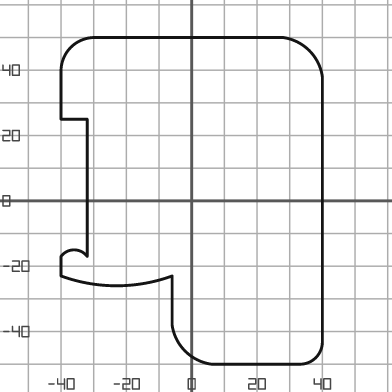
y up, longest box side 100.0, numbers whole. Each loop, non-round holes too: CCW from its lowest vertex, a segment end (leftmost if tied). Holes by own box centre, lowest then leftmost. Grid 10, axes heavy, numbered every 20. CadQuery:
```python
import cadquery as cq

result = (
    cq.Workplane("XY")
    .moveTo(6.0, -50.0)
    .lineTo(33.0, -50.0)
    .threePointArc((38.0, -48.0), (40.0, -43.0))
    .lineTo(40.0, 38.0)
    .threePointArc((36.0, 46.0), (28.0, 50.0))
    .lineTo(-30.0, 50.0)
    .threePointArc((-37.0, 47.0), (-40.0, 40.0))
    .lineTo(-40.0, 25.0)
    .lineTo(-32.0, 25.0)
    .lineTo(-32.0, -17.0)
    .threePointArc((-36.0, -15.0), (-40.0, -17.0))
    .lineTo(-40.0, -23.0)
    .threePointArc((-23.0, -26.0), (-6.0, -23.0))
    .lineTo(-6.0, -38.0)
    .threePointArc((-2.0, -46.0), (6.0, -50.0))
    .close()
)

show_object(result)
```